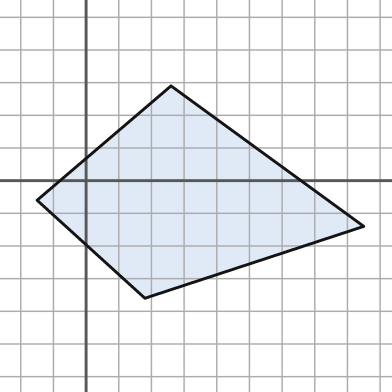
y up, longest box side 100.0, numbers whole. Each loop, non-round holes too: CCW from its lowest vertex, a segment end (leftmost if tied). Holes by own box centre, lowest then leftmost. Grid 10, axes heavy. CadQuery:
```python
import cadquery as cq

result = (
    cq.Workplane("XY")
    .moveTo(18.0, -36.0)
    .lineTo(85.0, -14.0)
    .lineTo(26.0, 29.0)
    .lineTo(-15.0, -6.0)
    .close()
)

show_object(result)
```